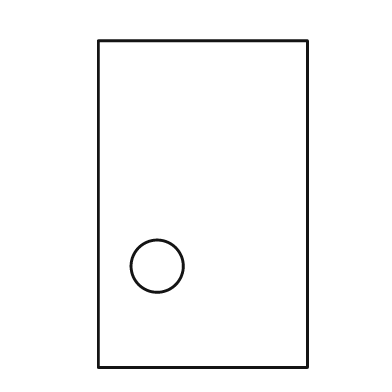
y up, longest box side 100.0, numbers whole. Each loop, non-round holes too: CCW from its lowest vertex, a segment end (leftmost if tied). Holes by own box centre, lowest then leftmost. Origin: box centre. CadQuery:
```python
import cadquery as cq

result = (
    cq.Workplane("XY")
    .moveTo(-32.0, -50.0)
    .lineTo(32.0, -50.0)
    .lineTo(32.0, 50.0)
    .lineTo(-32.0, 50.0)
    .close()
    .moveTo(-14.0, -19.0)
    .circle(8.0)
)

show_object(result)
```